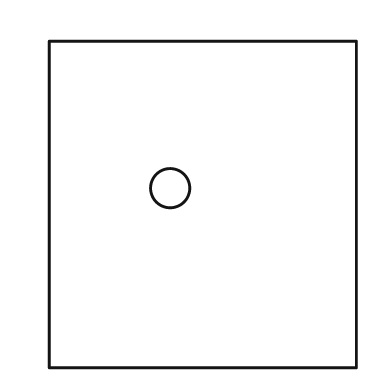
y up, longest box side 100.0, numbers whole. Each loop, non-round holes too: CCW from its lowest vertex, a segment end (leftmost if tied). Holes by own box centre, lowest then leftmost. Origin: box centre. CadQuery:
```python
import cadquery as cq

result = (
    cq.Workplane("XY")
    .moveTo(-47.0, -50.0)
    .lineTo(47.0, -50.0)
    .lineTo(47.0, 50.0)
    .lineTo(-47.0, 50.0)
    .close()
    .moveTo(-10.0, 5.0)
    .circle(6.0)
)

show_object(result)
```